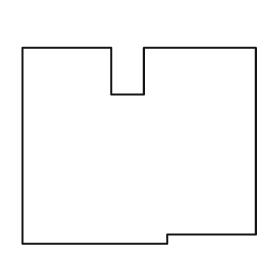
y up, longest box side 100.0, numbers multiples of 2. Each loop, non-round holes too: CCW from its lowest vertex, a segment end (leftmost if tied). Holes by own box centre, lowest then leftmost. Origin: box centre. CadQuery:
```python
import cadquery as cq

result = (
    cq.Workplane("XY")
    .moveTo(-50.0, -42.0)
    .lineTo(12.0, -42.0)
    .lineTo(12.0, -38.0)
    .lineTo(50.0, -38.0)
    .lineTo(50.0, 42.0)
    .lineTo(2.0, 42.0)
    .lineTo(2.0, 22.0)
    .lineTo(-12.0, 22.0)
    .lineTo(-12.0, 42.0)
    .lineTo(-50.0, 42.0)
    .close()
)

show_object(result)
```